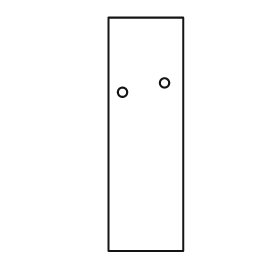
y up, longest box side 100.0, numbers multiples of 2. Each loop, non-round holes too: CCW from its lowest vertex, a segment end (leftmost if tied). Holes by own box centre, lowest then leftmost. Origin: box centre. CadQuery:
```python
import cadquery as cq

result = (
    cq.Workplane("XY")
    .moveTo(-16.0, -50.0)
    .lineTo(16.0, -50.0)
    .lineTo(16.0, 50.0)
    .lineTo(-16.0, 50.0)
    .close()
    .moveTo(-10.0, 18.0)
    .circle(2.0)
    .moveTo(8.0, 22.0)
    .circle(2.0)
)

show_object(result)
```